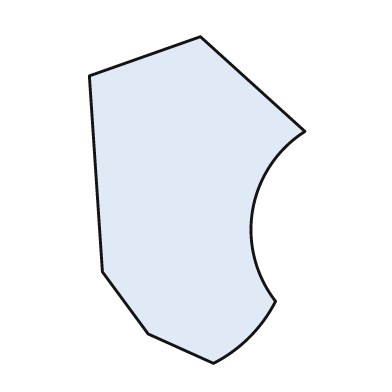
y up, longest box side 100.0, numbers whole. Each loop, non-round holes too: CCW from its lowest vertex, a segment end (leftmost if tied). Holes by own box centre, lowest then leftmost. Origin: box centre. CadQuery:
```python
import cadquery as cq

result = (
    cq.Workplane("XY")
    .moveTo(5.0, -50.0)
    .threePointArc((16.0, -42.0), (24.0, -31.0))
    .threePointArc((17.0, -3.0), (33.0, 21.0))
    .lineTo(1.0, 50.0)
    .lineTo(-33.0, 38.0)
    .lineTo(-29.0, -22.0)
    .lineTo(-15.0, -41.0)
    .close()
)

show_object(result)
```